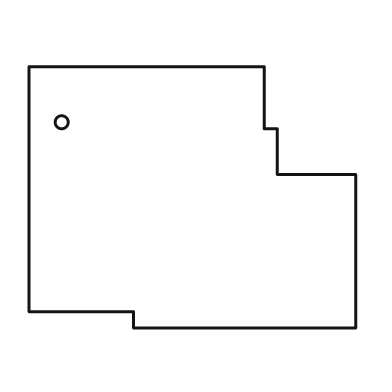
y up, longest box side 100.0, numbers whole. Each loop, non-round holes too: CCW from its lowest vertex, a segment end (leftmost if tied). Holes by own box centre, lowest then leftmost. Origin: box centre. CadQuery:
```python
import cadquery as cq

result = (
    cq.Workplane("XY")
    .moveTo(-18.0, -40.0)
    .lineTo(50.0, -40.0)
    .lineTo(50.0, 7.0)
    .lineTo(26.0, 7.0)
    .lineTo(26.0, 21.0)
    .lineTo(22.0, 21.0)
    .lineTo(22.0, 40.0)
    .lineTo(-50.0, 40.0)
    .lineTo(-50.0, -35.0)
    .lineTo(-18.0, -35.0)
    .close()
    .moveTo(-40.0, 23.0)
    .circle(2.0)
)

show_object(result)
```